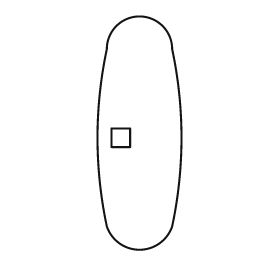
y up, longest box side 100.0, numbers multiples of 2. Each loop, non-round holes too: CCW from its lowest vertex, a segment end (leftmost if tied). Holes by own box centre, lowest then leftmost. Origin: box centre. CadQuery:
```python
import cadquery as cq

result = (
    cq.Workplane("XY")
    .moveTo(-14.0, -40.0)
    .threePointArc((0.0, -50.0), (14.0, -40.0))
    .threePointArc((18.0, -2.0), (14.0, 36.0))
    .threePointArc((0.0, 50.0), (-14.0, 36.0))
    .threePointArc((-18.0, -2.0), (-14.0, -40.0))
    .close()
    .moveTo(-12.0, -6.0)
    .lineTo(-4.0, -6.0)
    .lineTo(-4.0, 2.0)
    .lineTo(-12.0, 2.0)
    .close()
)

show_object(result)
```